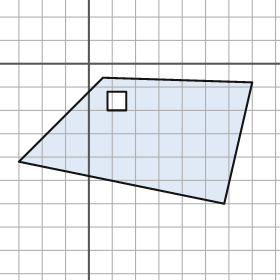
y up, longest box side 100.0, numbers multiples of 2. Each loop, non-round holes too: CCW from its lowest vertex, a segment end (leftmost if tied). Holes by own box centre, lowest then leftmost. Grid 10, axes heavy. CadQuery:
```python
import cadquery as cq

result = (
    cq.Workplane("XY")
    .moveTo(58.0, -60.0)
    .lineTo(70.0, -8.0)
    .lineTo(6.0, -6.0)
    .lineTo(-30.0, -42.0)
    .close()
    .moveTo(8.0, -20.0)
    .lineTo(16.0, -20.0)
    .lineTo(16.0, -12.0)
    .lineTo(8.0, -12.0)
    .close()
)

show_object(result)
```